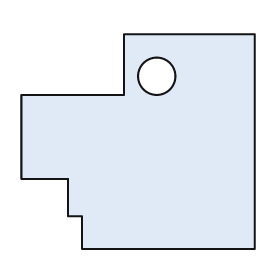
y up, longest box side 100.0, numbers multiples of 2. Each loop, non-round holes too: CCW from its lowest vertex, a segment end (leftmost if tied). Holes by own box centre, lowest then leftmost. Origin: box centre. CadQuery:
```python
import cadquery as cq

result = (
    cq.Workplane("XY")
    .moveTo(-24.0, -46.0)
    .lineTo(50.0, -46.0)
    .lineTo(50.0, 46.0)
    .lineTo(-6.0, 46.0)
    .lineTo(-6.0, 20.0)
    .lineTo(-50.0, 20.0)
    .lineTo(-50.0, -16.0)
    .lineTo(-30.0, -16.0)
    .lineTo(-30.0, -32.0)
    .lineTo(-24.0, -32.0)
    .close()
    .moveTo(8.0, 28.0)
    .circle(8.0)
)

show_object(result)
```